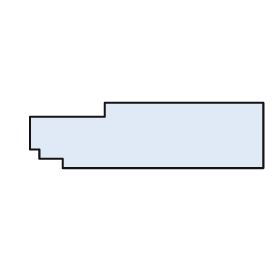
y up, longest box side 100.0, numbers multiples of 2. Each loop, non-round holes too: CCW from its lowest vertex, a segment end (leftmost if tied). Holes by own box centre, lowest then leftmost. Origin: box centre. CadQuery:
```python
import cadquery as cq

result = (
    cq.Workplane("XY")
    .moveTo(-36.0, -14.0)
    .lineTo(50.0, -14.0)
    .lineTo(50.0, 14.0)
    .lineTo(-18.0, 14.0)
    .lineTo(-18.0, 8.0)
    .lineTo(-50.0, 8.0)
    .lineTo(-50.0, -6.0)
    .lineTo(-46.0, -6.0)
    .lineTo(-46.0, -10.0)
    .lineTo(-36.0, -10.0)
    .close()
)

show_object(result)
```